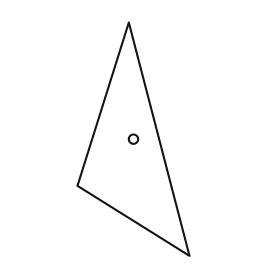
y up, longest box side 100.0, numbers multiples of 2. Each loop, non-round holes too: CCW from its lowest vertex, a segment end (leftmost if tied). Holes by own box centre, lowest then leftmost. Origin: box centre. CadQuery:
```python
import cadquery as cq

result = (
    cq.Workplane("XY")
    .moveTo(24.0, -50.0)
    .lineTo(-2.0, 50.0)
    .lineTo(-24.0, -20.0)
    .close()
    .moveTo(0.0, 0.0)
    .circle(2.0)
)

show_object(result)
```